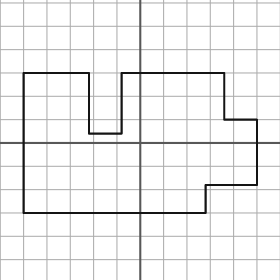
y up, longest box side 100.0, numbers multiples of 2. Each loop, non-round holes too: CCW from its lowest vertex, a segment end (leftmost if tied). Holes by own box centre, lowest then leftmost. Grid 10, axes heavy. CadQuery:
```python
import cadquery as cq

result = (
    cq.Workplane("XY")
    .moveTo(-50.0, -30.0)
    .lineTo(28.0, -30.0)
    .lineTo(28.0, -18.0)
    .lineTo(50.0, -18.0)
    .lineTo(50.0, 10.0)
    .lineTo(36.0, 10.0)
    .lineTo(36.0, 30.0)
    .lineTo(-8.0, 30.0)
    .lineTo(-8.0, 4.0)
    .lineTo(-22.0, 4.0)
    .lineTo(-22.0, 30.0)
    .lineTo(-50.0, 30.0)
    .close()
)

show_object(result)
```